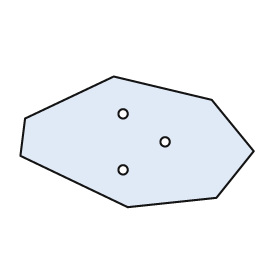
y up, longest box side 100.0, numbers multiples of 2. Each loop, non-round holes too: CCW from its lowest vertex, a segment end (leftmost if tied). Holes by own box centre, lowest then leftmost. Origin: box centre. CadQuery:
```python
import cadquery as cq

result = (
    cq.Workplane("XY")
    .moveTo(-4.0, -28.0)
    .lineTo(34.0, -24.0)
    .lineTo(50.0, -4.0)
    .lineTo(32.0, 18.0)
    .lineTo(-10.0, 28.0)
    .lineTo(-48.0, 10.0)
    .lineTo(-50.0, -6.0)
    .close()
    .moveTo(-6.0, -12.0)
    .circle(2.0)
    .moveTo(12.0, 0.0)
    .circle(2.0)
    .moveTo(-6.0, 12.0)
    .circle(2.0)
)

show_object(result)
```